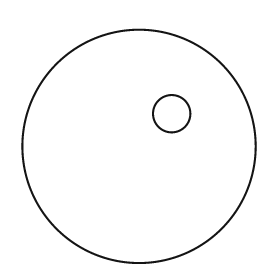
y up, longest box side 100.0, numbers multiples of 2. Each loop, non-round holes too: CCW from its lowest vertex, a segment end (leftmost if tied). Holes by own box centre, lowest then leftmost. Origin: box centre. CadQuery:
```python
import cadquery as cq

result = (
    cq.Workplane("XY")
    .moveTo(0.0, 0.0)
    .circle(50.0)
    .moveTo(14.0, 14.0)
    .circle(8.0)
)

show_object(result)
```